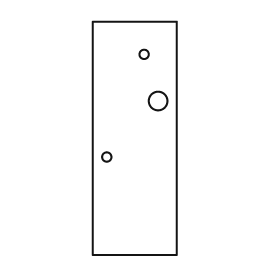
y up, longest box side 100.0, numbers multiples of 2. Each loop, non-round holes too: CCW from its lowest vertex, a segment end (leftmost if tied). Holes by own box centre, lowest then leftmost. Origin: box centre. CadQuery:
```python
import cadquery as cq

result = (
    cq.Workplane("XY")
    .moveTo(-18.0, -50.0)
    .lineTo(18.0, -50.0)
    .lineTo(18.0, 50.0)
    .lineTo(-18.0, 50.0)
    .close()
    .moveTo(-12.0, -8.0)
    .circle(2.0)
    .moveTo(10.0, 16.0)
    .circle(4.0)
    .moveTo(4.0, 36.0)
    .circle(2.0)
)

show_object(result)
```